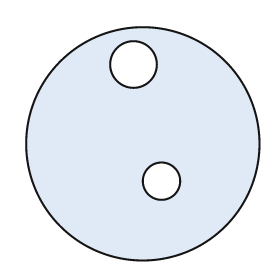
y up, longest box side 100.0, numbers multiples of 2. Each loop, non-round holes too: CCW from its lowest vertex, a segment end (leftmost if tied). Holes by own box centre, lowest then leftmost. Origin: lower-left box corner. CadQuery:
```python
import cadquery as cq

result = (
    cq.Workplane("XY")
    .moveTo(50.0, 50.0)
    .circle(50.0)
    .moveTo(58.0, 34.0)
    .circle(8.0)
    .moveTo(46.0, 84.0)
    .circle(10.0)
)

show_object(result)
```